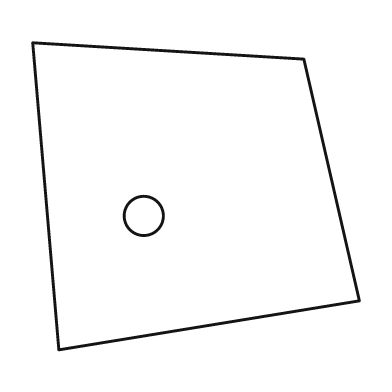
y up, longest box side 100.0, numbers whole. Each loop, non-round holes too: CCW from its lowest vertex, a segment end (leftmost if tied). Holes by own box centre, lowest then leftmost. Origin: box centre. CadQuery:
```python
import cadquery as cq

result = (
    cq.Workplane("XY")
    .moveTo(-42.0, -47.0)
    .lineTo(50.0, -32.0)
    .lineTo(33.0, 42.0)
    .lineTo(-50.0, 47.0)
    .close()
    .moveTo(-16.0, -6.0)
    .circle(6.0)
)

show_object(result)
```